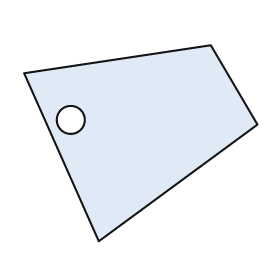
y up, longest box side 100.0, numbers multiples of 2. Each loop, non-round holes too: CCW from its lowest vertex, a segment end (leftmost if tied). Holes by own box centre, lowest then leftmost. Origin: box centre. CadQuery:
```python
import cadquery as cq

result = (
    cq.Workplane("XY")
    .moveTo(-18.0, -42.0)
    .lineTo(50.0, 8.0)
    .lineTo(30.0, 42.0)
    .lineTo(-50.0, 30.0)
    .close()
    .moveTo(-30.0, 10.0)
    .circle(6.0)
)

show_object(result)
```